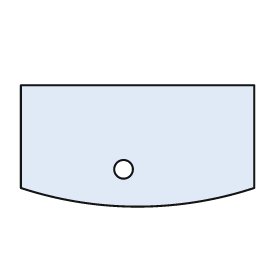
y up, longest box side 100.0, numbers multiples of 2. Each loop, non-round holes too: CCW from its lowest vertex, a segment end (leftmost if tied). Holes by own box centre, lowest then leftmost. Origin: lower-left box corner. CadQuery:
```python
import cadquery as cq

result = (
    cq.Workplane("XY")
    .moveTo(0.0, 8.0)
    .threePointArc((50.0, 0.0), (100.0, 8.0))
    .lineTo(100.0, 52.0)
    .lineTo(0.0, 52.0)
    .close()
    .moveTo(44.0, 16.0)
    .circle(4.0)
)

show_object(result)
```